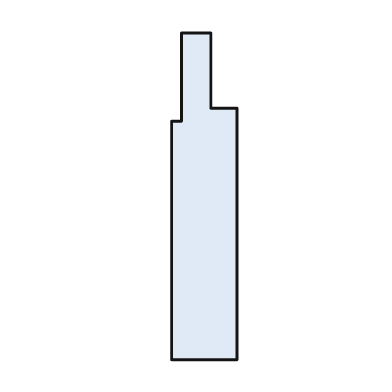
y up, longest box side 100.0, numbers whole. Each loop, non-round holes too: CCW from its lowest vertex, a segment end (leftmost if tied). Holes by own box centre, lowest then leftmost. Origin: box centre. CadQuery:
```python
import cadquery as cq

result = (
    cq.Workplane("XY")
    .moveTo(-10.0, -50.0)
    .lineTo(10.0, -50.0)
    .lineTo(10.0, 27.0)
    .lineTo(2.0, 27.0)
    .lineTo(2.0, 50.0)
    .lineTo(-7.0, 50.0)
    .lineTo(-7.0, 23.0)
    .lineTo(-10.0, 23.0)
    .close()
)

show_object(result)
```